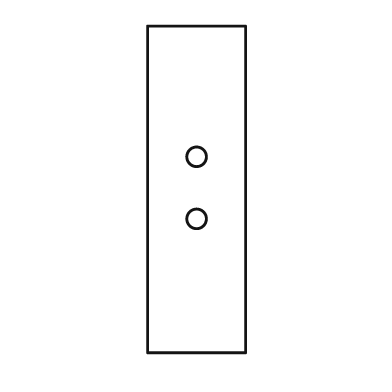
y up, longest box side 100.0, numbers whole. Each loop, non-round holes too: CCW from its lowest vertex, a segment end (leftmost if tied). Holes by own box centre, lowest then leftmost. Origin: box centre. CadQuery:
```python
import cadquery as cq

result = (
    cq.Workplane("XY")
    .moveTo(-15.0, -50.0)
    .lineTo(15.0, -50.0)
    .lineTo(15.0, 50.0)
    .lineTo(-15.0, 50.0)
    .close()
    .moveTo(0.0, -9.0)
    .circle(3.0)
    .moveTo(0.0, 10.0)
    .circle(3.0)
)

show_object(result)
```